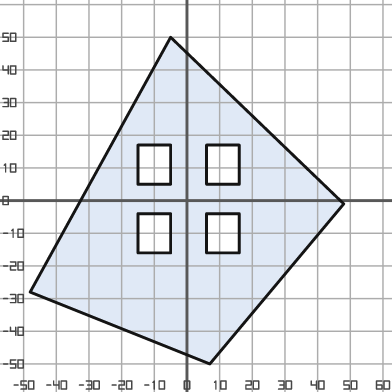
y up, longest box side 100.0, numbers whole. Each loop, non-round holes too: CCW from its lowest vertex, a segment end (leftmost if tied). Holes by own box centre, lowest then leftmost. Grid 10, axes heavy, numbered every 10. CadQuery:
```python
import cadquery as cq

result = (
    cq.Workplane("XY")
    .moveTo(7.0, -50.0)
    .lineTo(48.0, -1.0)
    .lineTo(-5.0, 50.0)
    .lineTo(-48.0, -28.0)
    .close()
    .moveTo(-15.0, -16.0)
    .lineTo(-5.0, -16.0)
    .lineTo(-5.0, -4.0)
    .lineTo(-15.0, -4.0)
    .close()
    .moveTo(6.0, -16.0)
    .lineTo(16.0, -16.0)
    .lineTo(16.0, -4.0)
    .lineTo(6.0, -4.0)
    .close()
    .moveTo(-15.0, 5.0)
    .lineTo(-5.0, 5.0)
    .lineTo(-5.0, 17.0)
    .lineTo(-15.0, 17.0)
    .close()
    .moveTo(6.0, 5.0)
    .lineTo(16.0, 5.0)
    .lineTo(16.0, 17.0)
    .lineTo(6.0, 17.0)
    .close()
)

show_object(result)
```